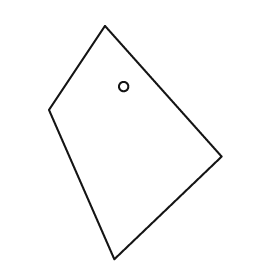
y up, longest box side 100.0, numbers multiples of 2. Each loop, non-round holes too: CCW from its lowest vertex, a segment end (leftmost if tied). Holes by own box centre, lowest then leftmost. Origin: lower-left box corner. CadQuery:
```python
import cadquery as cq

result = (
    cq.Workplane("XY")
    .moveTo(28.0, 0.0)
    .lineTo(74.0, 44.0)
    .lineTo(24.0, 100.0)
    .lineTo(0.0, 64.0)
    .close()
    .moveTo(32.0, 74.0)
    .circle(2.0)
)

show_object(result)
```